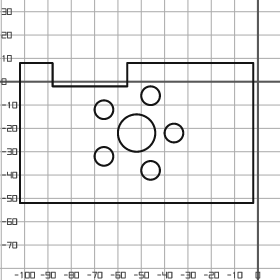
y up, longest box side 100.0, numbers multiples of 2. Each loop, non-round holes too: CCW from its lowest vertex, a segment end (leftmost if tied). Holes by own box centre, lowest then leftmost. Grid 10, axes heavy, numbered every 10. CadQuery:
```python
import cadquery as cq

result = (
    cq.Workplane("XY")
    .moveTo(-102.0, -52.0)
    .lineTo(-2.0, -52.0)
    .lineTo(-2.0, 8.0)
    .lineTo(-56.0, 8.0)
    .lineTo(-56.0, -2.0)
    .lineTo(-88.0, -2.0)
    .lineTo(-88.0, 8.0)
    .lineTo(-102.0, 8.0)
    .close()
    .moveTo(-46.0, -38.0)
    .circle(4.0)
    .moveTo(-66.0, -32.0)
    .circle(4.0)
    .moveTo(-52.0, -22.0)
    .circle(8.0)
    .moveTo(-36.0, -22.0)
    .circle(4.0)
    .moveTo(-66.0, -12.0)
    .circle(4.0)
    .moveTo(-46.0, -6.0)
    .circle(4.0)
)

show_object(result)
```